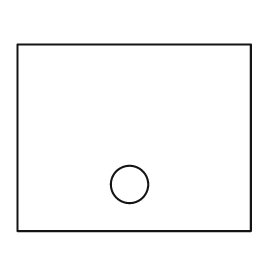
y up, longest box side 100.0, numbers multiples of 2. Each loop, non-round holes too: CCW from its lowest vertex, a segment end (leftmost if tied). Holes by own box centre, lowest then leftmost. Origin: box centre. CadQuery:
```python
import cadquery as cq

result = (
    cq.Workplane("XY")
    .moveTo(-50.0, -40.0)
    .lineTo(50.0, -40.0)
    .lineTo(50.0, 40.0)
    .lineTo(-50.0, 40.0)
    .close()
    .moveTo(-2.0, -20.0)
    .circle(8.0)
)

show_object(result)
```